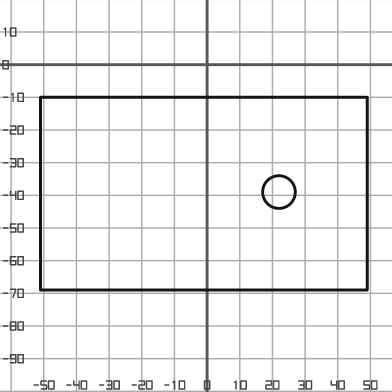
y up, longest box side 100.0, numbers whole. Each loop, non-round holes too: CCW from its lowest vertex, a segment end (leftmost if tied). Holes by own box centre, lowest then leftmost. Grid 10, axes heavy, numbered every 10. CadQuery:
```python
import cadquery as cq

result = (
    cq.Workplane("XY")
    .moveTo(-51.0, -69.0)
    .lineTo(49.0, -69.0)
    .lineTo(49.0, -10.0)
    .lineTo(-51.0, -10.0)
    .close()
    .moveTo(22.0, -39.0)
    .circle(5.0)
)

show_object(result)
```